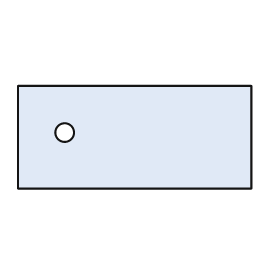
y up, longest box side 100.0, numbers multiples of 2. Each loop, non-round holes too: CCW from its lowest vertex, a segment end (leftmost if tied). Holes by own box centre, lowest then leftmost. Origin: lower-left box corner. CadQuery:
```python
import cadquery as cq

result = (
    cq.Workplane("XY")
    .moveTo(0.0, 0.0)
    .lineTo(100.0, 0.0)
    .lineTo(100.0, 44.0)
    .lineTo(0.0, 44.0)
    .close()
    .moveTo(20.0, 24.0)
    .circle(4.0)
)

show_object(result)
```